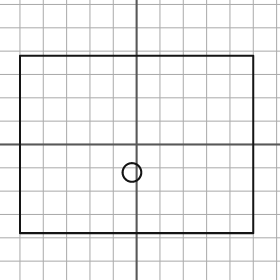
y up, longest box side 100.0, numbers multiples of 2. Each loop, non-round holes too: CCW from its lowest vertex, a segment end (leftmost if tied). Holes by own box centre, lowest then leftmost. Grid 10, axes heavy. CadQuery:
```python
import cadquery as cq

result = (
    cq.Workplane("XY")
    .moveTo(-50.0, -38.0)
    .lineTo(50.0, -38.0)
    .lineTo(50.0, 38.0)
    .lineTo(-50.0, 38.0)
    .close()
    .moveTo(-2.0, -12.0)
    .circle(4.0)
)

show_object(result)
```